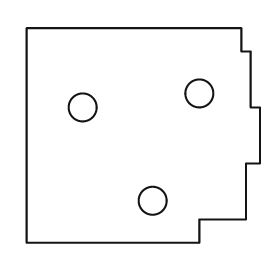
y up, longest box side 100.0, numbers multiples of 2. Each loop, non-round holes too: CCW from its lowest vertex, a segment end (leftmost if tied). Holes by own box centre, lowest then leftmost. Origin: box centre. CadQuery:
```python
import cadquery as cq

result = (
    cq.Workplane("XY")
    .moveTo(-50.0, -46.0)
    .lineTo(24.0, -46.0)
    .lineTo(24.0, -36.0)
    .lineTo(44.0, -36.0)
    .lineTo(44.0, -12.0)
    .lineTo(50.0, -12.0)
    .lineTo(50.0, 12.0)
    .lineTo(46.0, 12.0)
    .lineTo(46.0, 36.0)
    .lineTo(42.0, 36.0)
    .lineTo(42.0, 46.0)
    .lineTo(-50.0, 46.0)
    .close()
    .moveTo(4.0, -28.0)
    .circle(6.0)
    .moveTo(-26.0, 12.0)
    .circle(6.0)
    .moveTo(24.0, 18.0)
    .circle(6.0)
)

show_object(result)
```